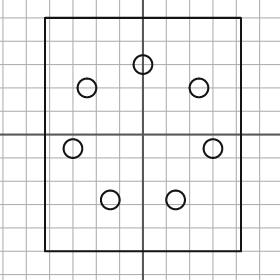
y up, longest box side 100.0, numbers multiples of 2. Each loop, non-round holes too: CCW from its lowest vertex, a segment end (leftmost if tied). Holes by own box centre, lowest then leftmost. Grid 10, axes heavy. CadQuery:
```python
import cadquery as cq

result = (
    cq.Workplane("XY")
    .moveTo(-42.0, -50.0)
    .lineTo(42.0, -50.0)
    .lineTo(42.0, 50.0)
    .lineTo(-42.0, 50.0)
    .close()
    .moveTo(-14.0, -28.0)
    .circle(4.0)
    .moveTo(14.0, -28.0)
    .circle(4.0)
    .moveTo(-30.0, -6.0)
    .circle(4.0)
    .moveTo(30.0, -6.0)
    .circle(4.0)
    .moveTo(-24.0, 20.0)
    .circle(4.0)
    .moveTo(24.0, 20.0)
    .circle(4.0)
    .moveTo(0.0, 30.0)
    .circle(4.0)
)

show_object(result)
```